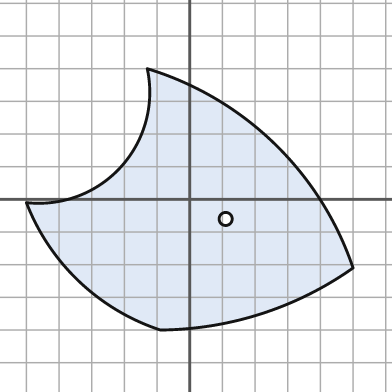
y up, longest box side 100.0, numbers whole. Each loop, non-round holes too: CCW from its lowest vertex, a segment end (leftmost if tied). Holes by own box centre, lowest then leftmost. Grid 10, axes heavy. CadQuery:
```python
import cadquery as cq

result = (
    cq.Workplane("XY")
    .moveTo(-9.0, -40.0)
    .threePointArc((22.0, -35.0), (50.0, -21.0))
    .threePointArc((26.0, 17.0), (-13.0, 40.0))
    .threePointArc((-21.0, 10.0), (-50.0, -1.0))
    .threePointArc((-34.0, -25.0), (-9.0, -40.0))
    .close()
    .moveTo(11.0, -6.0)
    .circle(2.0)
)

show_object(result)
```